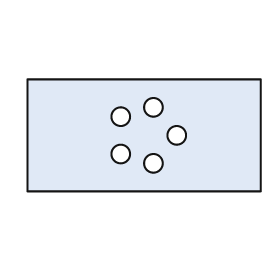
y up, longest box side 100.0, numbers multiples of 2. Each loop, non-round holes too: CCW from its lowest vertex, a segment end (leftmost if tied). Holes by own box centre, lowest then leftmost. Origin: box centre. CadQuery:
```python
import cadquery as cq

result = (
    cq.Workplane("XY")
    .moveTo(-50.0, -24.0)
    .lineTo(50.0, -24.0)
    .lineTo(50.0, 24.0)
    .lineTo(-50.0, 24.0)
    .close()
    .moveTo(4.0, -12.0)
    .circle(4.0)
    .moveTo(-10.0, -8.0)
    .circle(4.0)
    .moveTo(14.0, 0.0)
    .circle(4.0)
    .moveTo(-10.0, 8.0)
    .circle(4.0)
    .moveTo(4.0, 12.0)
    .circle(4.0)
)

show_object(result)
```